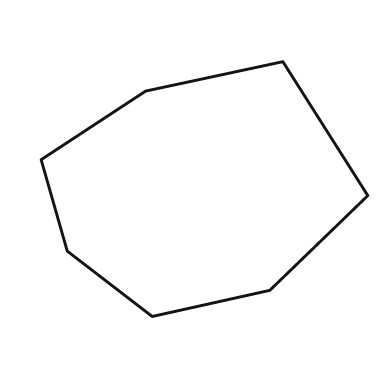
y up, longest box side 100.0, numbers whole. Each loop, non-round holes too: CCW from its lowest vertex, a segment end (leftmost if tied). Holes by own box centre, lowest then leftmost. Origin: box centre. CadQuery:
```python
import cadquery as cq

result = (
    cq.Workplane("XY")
    .moveTo(-16.0, -39.0)
    .lineTo(20.0, -31.0)
    .lineTo(50.0, -2.0)
    .lineTo(24.0, 39.0)
    .lineTo(-18.0, 30.0)
    .lineTo(-50.0, 9.0)
    .lineTo(-42.0, -19.0)
    .close()
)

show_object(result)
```